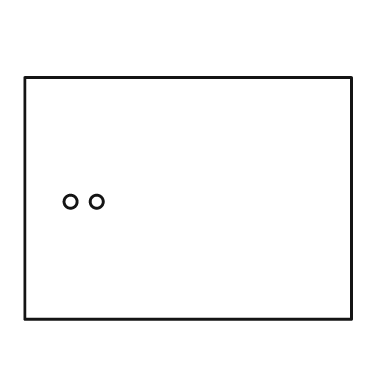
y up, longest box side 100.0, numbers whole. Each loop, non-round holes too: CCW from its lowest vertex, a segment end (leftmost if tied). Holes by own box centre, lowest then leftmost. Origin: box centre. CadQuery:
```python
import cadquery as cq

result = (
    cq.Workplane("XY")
    .moveTo(-50.0, -37.0)
    .lineTo(50.0, -37.0)
    .lineTo(50.0, 37.0)
    .lineTo(-50.0, 37.0)
    .close()
    .moveTo(-36.0, -1.0)
    .circle(2.0)
    .moveTo(-28.0, -1.0)
    .circle(2.0)
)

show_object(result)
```